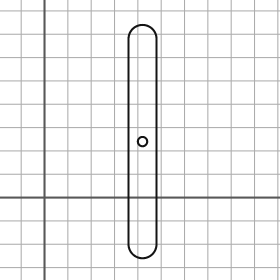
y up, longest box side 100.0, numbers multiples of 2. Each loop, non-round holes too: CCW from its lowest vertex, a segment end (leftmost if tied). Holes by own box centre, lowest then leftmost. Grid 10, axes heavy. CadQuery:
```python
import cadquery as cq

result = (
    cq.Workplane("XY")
    .moveTo(36.0, -20.0)
    .threePointArc((42.0, -26.0), (48.0, -20.0))
    .lineTo(48.0, 68.0)
    .threePointArc((42.0, 74.0), (36.0, 68.0))
    .close()
    .moveTo(42.0, 24.0)
    .circle(2.0)
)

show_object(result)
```